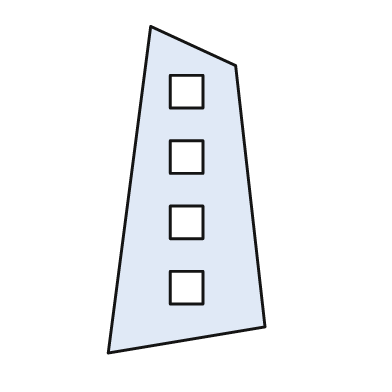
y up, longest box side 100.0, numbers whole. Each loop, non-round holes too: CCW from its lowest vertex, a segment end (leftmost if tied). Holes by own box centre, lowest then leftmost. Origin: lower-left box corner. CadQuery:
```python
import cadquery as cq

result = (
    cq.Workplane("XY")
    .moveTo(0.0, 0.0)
    .lineTo(48.0, 8.0)
    .lineTo(39.0, 88.0)
    .lineTo(13.0, 100.0)
    .close()
    .moveTo(19.0, 15.0)
    .lineTo(29.0, 15.0)
    .lineTo(29.0, 25.0)
    .lineTo(19.0, 25.0)
    .close()
    .moveTo(19.0, 35.0)
    .lineTo(29.0, 35.0)
    .lineTo(29.0, 45.0)
    .lineTo(19.0, 45.0)
    .close()
    .moveTo(19.0, 55.0)
    .lineTo(29.0, 55.0)
    .lineTo(29.0, 65.0)
    .lineTo(19.0, 65.0)
    .close()
    .moveTo(19.0, 75.0)
    .lineTo(29.0, 75.0)
    .lineTo(29.0, 85.0)
    .lineTo(19.0, 85.0)
    .close()
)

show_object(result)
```